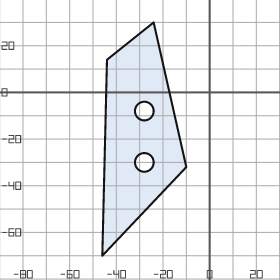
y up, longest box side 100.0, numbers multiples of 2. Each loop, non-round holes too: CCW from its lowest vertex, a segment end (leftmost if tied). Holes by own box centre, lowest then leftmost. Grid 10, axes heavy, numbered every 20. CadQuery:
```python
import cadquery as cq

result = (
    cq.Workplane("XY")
    .moveTo(-46.0, -70.0)
    .lineTo(-10.0, -32.0)
    .lineTo(-24.0, 30.0)
    .lineTo(-44.0, 14.0)
    .close()
    .moveTo(-28.0, -30.0)
    .circle(4.0)
    .moveTo(-28.0, -8.0)
    .circle(4.0)
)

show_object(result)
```